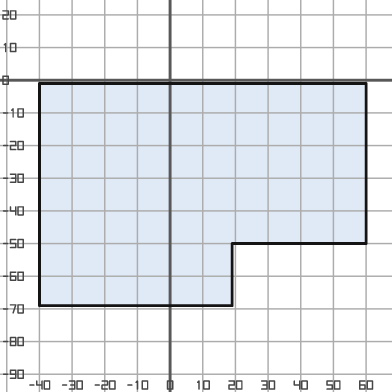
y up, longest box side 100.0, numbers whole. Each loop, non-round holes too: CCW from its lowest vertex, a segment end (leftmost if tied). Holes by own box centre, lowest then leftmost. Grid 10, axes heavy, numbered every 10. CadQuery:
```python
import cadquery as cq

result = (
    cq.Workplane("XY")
    .moveTo(-40.0, -69.0)
    .lineTo(19.0, -69.0)
    .lineTo(19.0, -50.0)
    .lineTo(60.0, -50.0)
    .lineTo(60.0, -1.0)
    .lineTo(-40.0, -1.0)
    .close()
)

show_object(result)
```